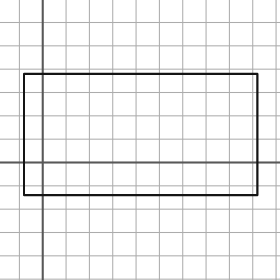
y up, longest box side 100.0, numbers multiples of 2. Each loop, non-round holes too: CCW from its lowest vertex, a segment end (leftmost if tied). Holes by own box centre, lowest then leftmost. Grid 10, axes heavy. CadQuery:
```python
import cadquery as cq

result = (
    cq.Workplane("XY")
    .moveTo(-8.0, -14.0)
    .lineTo(92.0, -14.0)
    .lineTo(92.0, 38.0)
    .lineTo(-8.0, 38.0)
    .close()
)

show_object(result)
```